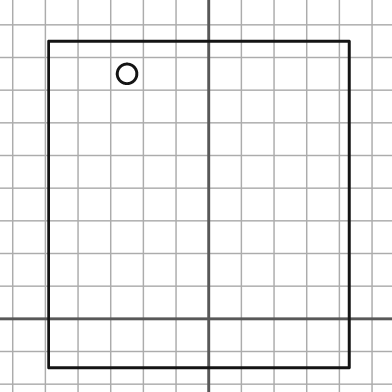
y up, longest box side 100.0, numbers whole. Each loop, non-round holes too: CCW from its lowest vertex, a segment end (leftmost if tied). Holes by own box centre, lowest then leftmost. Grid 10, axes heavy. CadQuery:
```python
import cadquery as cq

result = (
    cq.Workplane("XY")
    .moveTo(-49.0, -15.0)
    .lineTo(43.0, -15.0)
    .lineTo(43.0, 85.0)
    .lineTo(-49.0, 85.0)
    .close()
    .moveTo(-25.0, 75.0)
    .circle(3.0)
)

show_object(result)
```